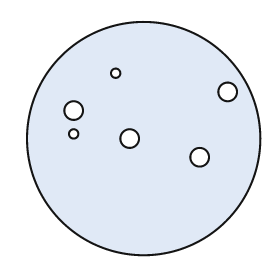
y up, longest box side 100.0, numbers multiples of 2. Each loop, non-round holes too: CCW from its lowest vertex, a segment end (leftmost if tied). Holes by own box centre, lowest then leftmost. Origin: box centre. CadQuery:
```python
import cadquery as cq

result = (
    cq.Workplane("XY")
    .moveTo(0.0, 0.0)
    .circle(50.0)
    .moveTo(24.0, -8.0)
    .circle(4.0)
    .moveTo(-6.0, 0.0)
    .circle(4.0)
    .moveTo(-30.0, 2.0)
    .circle(2.0)
    .moveTo(-30.0, 12.0)
    .circle(4.0)
    .moveTo(36.0, 20.0)
    .circle(4.0)
    .moveTo(-12.0, 28.0)
    .circle(2.0)
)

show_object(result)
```